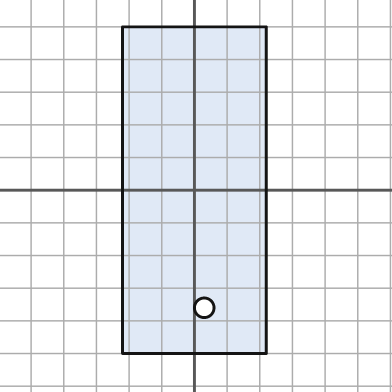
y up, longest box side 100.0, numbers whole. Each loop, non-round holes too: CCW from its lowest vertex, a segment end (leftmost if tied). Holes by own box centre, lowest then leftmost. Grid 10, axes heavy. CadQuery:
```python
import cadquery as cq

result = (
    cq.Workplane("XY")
    .moveTo(-22.0, -50.0)
    .lineTo(22.0, -50.0)
    .lineTo(22.0, 50.0)
    .lineTo(-22.0, 50.0)
    .close()
    .moveTo(3.0, -36.0)
    .circle(3.0)
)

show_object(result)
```